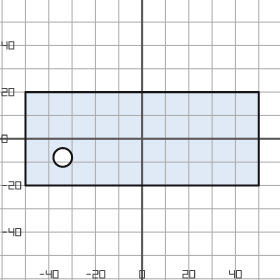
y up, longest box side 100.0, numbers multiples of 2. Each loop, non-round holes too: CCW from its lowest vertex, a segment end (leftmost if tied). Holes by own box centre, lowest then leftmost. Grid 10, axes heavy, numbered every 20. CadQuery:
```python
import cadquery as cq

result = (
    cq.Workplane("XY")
    .moveTo(-50.0, -20.0)
    .lineTo(50.0, -20.0)
    .lineTo(50.0, 20.0)
    .lineTo(-50.0, 20.0)
    .close()
    .moveTo(-34.0, -8.0)
    .circle(4.0)
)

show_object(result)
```